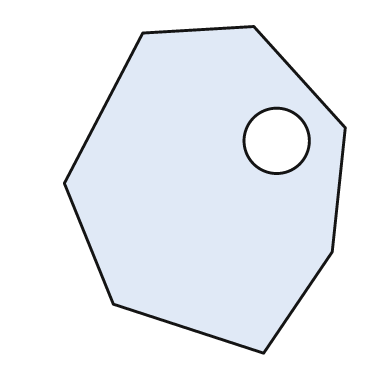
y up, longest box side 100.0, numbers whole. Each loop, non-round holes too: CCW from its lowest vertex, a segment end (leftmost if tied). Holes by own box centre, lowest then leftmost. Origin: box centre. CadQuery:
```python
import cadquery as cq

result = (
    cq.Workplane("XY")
    .moveTo(18.0, -50.0)
    .lineTo(39.0, -19.0)
    .lineTo(43.0, 19.0)
    .lineTo(15.0, 50.0)
    .lineTo(-19.0, 48.0)
    .lineTo(-43.0, 2.0)
    .lineTo(-28.0, -35.0)
    .close()
    .moveTo(22.0, 15.0)
    .circle(10.0)
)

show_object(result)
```